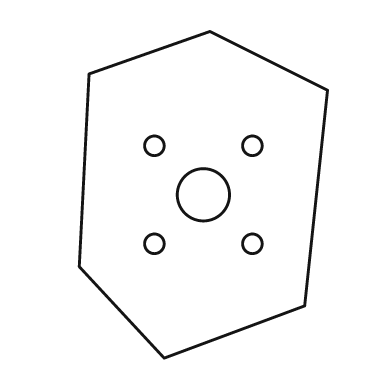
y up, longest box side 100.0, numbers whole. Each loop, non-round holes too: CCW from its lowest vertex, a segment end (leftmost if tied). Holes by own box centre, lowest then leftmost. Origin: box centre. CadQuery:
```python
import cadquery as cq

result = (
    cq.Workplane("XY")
    .moveTo(-12.0, -50.0)
    .lineTo(31.0, -34.0)
    .lineTo(38.0, 32.0)
    .lineTo(2.0, 50.0)
    .lineTo(-35.0, 37.0)
    .lineTo(-38.0, -22.0)
    .close()
    .moveTo(-15.0, -15.0)
    .circle(3.0)
    .moveTo(15.0, -15.0)
    .circle(3.0)
    .moveTo(0.0, 0.0)
    .circle(8.0)
    .moveTo(-15.0, 15.0)
    .circle(3.0)
    .moveTo(15.0, 15.0)
    .circle(3.0)
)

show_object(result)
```